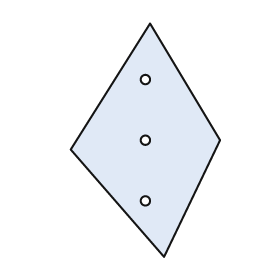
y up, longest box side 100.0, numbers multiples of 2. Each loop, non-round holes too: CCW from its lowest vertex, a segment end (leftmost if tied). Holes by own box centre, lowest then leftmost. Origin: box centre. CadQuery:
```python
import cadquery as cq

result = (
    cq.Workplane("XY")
    .moveTo(8.0, -50.0)
    .lineTo(32.0, 0.0)
    .lineTo(2.0, 50.0)
    .lineTo(-32.0, -4.0)
    .close()
    .moveTo(0.0, -26.0)
    .circle(2.0)
    .moveTo(0.0, 0.0)
    .circle(2.0)
    .moveTo(0.0, 26.0)
    .circle(2.0)
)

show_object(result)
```